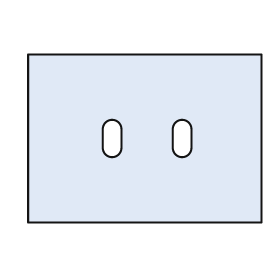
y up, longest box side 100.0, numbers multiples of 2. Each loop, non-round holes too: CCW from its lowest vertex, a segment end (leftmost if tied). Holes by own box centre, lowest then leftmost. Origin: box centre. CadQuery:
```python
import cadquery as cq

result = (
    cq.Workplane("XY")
    .moveTo(-50.0, -36.0)
    .lineTo(50.0, -36.0)
    .lineTo(50.0, 36.0)
    .lineTo(-50.0, 36.0)
    .close()
    .moveTo(-18.0, -4.0)
    .threePointArc((-14.0, -8.0), (-10.0, -4.0))
    .lineTo(-10.0, 4.0)
    .threePointArc((-14.0, 8.0), (-18.0, 4.0))
    .close()
    .moveTo(12.0, -4.0)
    .threePointArc((16.0, -8.0), (20.0, -4.0))
    .lineTo(20.0, 4.0)
    .threePointArc((16.0, 8.0), (12.0, 4.0))
    .close()
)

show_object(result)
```